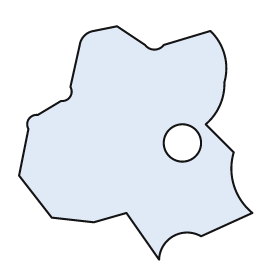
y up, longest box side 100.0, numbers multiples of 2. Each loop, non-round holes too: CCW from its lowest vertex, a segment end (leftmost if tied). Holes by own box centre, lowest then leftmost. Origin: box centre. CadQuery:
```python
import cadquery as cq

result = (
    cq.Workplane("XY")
    .moveTo(10.0, -50.0)
    .threePointArc((16.0, -40.0), (28.0, -40.0))
    .lineTo(50.0, -30.0)
    .threePointArc((42.0, -18.0), (42.0, -4.0))
    .lineTo(30.0, 8.0)
    .threePointArc((36.0, 16.0), (38.0, 26.0))
    .threePointArc((38.0, 38.0), (32.0, 48.0))
    .lineTo(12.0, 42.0)
    .threePointArc((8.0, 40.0), (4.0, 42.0))
    .lineTo(-8.0, 50.0)
    .lineTo(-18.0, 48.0)
    .threePointArc((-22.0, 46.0), (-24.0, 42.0))
    .lineTo(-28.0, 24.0)
    .threePointArc((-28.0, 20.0), (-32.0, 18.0))
    .lineTo(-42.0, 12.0)
    .threePointArc((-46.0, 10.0), (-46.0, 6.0))
    .lineTo(-50.0, -14.0)
    .lineTo(-36.0, -32.0)
    .lineTo(-18.0, -34.0)
    .lineTo(-4.0, -30.0)
    .close()
    .moveTo(20.0, 0.0)
    .circle(8.0)
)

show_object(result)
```